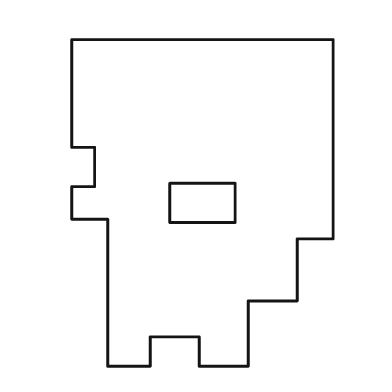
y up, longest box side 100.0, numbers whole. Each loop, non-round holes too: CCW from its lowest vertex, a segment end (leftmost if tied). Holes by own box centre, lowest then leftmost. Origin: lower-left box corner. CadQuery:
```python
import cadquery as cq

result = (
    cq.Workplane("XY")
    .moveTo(11.0, 0.0)
    .lineTo(24.0, 0.0)
    .lineTo(24.0, 9.0)
    .lineTo(39.0, 9.0)
    .lineTo(39.0, 0.0)
    .lineTo(54.0, 0.0)
    .lineTo(54.0, 20.0)
    .lineTo(69.0, 20.0)
    .lineTo(69.0, 39.0)
    .lineTo(80.0, 39.0)
    .lineTo(80.0, 100.0)
    .lineTo(0.0, 100.0)
    .lineTo(0.0, 67.0)
    .lineTo(7.0, 67.0)
    .lineTo(7.0, 55.0)
    .lineTo(0.0, 55.0)
    .lineTo(0.0, 45.0)
    .lineTo(11.0, 45.0)
    .close()
    .moveTo(30.0, 44.0)
    .lineTo(50.0, 44.0)
    .lineTo(50.0, 56.0)
    .lineTo(30.0, 56.0)
    .close()
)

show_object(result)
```